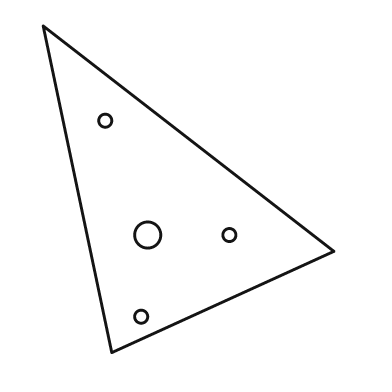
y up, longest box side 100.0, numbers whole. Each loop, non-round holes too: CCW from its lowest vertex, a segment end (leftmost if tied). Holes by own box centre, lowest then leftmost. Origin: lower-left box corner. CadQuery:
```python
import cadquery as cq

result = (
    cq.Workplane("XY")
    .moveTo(21.0, 0.0)
    .lineTo(89.0, 31.0)
    .lineTo(0.0, 100.0)
    .close()
    .moveTo(30.0, 11.0)
    .circle(2.0)
    .moveTo(32.0, 36.0)
    .circle(4.0)
    .moveTo(57.0, 36.0)
    .circle(2.0)
    .moveTo(19.0, 71.0)
    .circle(2.0)
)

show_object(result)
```